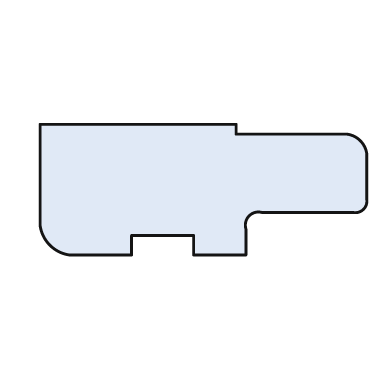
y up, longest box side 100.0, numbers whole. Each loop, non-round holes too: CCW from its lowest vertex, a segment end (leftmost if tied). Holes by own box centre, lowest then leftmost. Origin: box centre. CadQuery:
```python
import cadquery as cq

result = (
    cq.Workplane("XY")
    .moveTo(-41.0, -20.0)
    .lineTo(-22.0, -20.0)
    .lineTo(-22.0, -14.0)
    .lineTo(-3.0, -14.0)
    .lineTo(-3.0, -20.0)
    .lineTo(13.0, -20.0)
    .lineTo(13.0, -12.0)
    .threePointArc((14.0, -8.0), (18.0, -7.0))
    .lineTo(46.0, -7.0)
    .threePointArc((49.0, -6.0), (50.0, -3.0))
    .lineTo(50.0, 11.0)
    .threePointArc((48.0, 15.0), (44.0, 17.0))
    .lineTo(10.0, 17.0)
    .lineTo(10.0, 20.0)
    .lineTo(-50.0, 20.0)
    .lineTo(-50.0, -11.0)
    .threePointArc((-47.0, -17.0), (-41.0, -20.0))
    .close()
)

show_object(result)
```